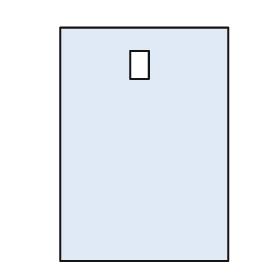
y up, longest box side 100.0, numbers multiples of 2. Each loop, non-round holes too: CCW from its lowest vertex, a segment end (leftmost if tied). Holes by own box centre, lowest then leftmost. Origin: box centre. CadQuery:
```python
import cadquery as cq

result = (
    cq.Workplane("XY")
    .moveTo(-36.0, -50.0)
    .lineTo(36.0, -50.0)
    .lineTo(36.0, 50.0)
    .lineTo(-36.0, 50.0)
    .close()
    .moveTo(-6.0, 28.0)
    .lineTo(2.0, 28.0)
    .lineTo(2.0, 40.0)
    .lineTo(-6.0, 40.0)
    .close()
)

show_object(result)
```